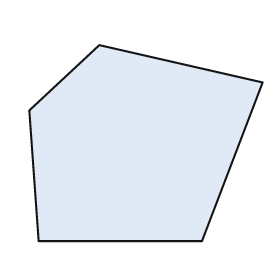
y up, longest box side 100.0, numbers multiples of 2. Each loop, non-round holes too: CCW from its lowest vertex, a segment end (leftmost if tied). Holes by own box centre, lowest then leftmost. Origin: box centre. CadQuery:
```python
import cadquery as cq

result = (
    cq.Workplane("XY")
    .moveTo(-46.0, -42.0)
    .lineTo(24.0, -42.0)
    .lineTo(50.0, 26.0)
    .lineTo(-20.0, 42.0)
    .lineTo(-50.0, 14.0)
    .close()
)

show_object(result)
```